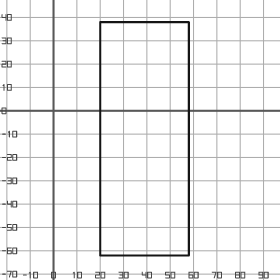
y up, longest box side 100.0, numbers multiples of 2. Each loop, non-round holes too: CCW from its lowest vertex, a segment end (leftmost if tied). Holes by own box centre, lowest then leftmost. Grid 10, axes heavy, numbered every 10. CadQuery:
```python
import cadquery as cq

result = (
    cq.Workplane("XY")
    .moveTo(20.0, -62.0)
    .lineTo(58.0, -62.0)
    .lineTo(58.0, 38.0)
    .lineTo(20.0, 38.0)
    .close()
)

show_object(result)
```